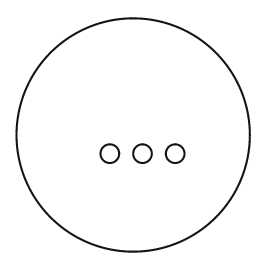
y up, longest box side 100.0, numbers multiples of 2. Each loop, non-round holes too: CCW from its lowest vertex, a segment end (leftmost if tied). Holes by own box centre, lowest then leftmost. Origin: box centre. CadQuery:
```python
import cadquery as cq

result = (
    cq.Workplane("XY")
    .moveTo(0.0, 0.0)
    .circle(50.0)
    .moveTo(-10.0, -8.0)
    .circle(4.0)
    .moveTo(4.0, -8.0)
    .circle(4.0)
    .moveTo(18.0, -8.0)
    .circle(4.0)
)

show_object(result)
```